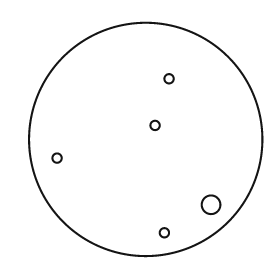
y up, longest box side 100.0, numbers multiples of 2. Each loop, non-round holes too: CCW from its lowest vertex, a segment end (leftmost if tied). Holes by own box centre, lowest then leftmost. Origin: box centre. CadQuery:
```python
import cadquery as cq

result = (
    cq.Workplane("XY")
    .moveTo(0.0, 0.0)
    .circle(50.0)
    .moveTo(8.0, -40.0)
    .circle(2.0)
    .moveTo(28.0, -28.0)
    .circle(4.0)
    .moveTo(-38.0, -8.0)
    .circle(2.0)
    .moveTo(4.0, 6.0)
    .circle(2.0)
    .moveTo(10.0, 26.0)
    .circle(2.0)
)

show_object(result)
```